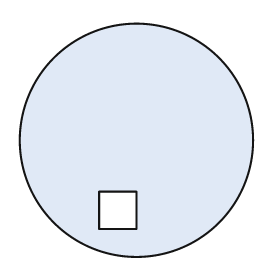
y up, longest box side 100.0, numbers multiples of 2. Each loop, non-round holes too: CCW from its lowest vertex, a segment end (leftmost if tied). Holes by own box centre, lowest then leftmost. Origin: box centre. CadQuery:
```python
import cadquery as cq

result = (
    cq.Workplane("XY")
    .moveTo(0.0, 0.0)
    .circle(50.0)
    .moveTo(-16.0, -38.0)
    .lineTo(0.0, -38.0)
    .lineTo(0.0, -22.0)
    .lineTo(-16.0, -22.0)
    .close()
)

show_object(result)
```